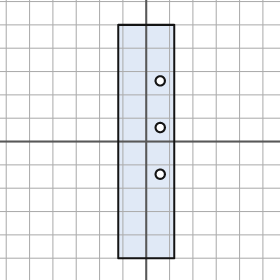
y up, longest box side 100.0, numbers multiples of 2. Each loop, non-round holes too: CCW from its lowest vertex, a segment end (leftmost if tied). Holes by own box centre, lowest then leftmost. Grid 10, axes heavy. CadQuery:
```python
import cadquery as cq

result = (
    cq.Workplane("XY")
    .moveTo(-12.0, -50.0)
    .lineTo(12.0, -50.0)
    .lineTo(12.0, 50.0)
    .lineTo(-12.0, 50.0)
    .close()
    .moveTo(6.0, -14.0)
    .circle(2.0)
    .moveTo(6.0, 6.0)
    .circle(2.0)
    .moveTo(6.0, 26.0)
    .circle(2.0)
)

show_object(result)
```